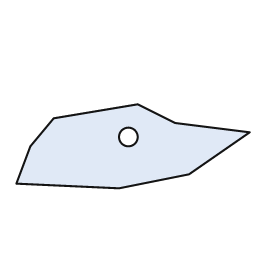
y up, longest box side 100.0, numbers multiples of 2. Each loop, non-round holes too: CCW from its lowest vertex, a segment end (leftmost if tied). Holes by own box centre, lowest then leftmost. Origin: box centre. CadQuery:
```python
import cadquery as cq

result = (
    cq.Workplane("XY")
    .moveTo(-6.0, -18.0)
    .lineTo(24.0, -12.0)
    .lineTo(50.0, 6.0)
    .lineTo(18.0, 10.0)
    .lineTo(2.0, 18.0)
    .lineTo(-34.0, 12.0)
    .lineTo(-44.0, 0.0)
    .lineTo(-50.0, -16.0)
    .close()
    .moveTo(-2.0, 4.0)
    .circle(4.0)
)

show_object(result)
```